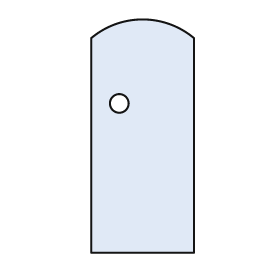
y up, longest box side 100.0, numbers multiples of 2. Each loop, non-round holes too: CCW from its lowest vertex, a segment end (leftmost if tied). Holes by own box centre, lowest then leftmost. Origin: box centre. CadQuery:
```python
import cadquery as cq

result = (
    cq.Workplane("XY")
    .moveTo(-22.0, -50.0)
    .lineTo(22.0, -50.0)
    .lineTo(22.0, 42.0)
    .threePointArc((0.0, 50.0), (-22.0, 42.0))
    .close()
    .moveTo(-10.0, 14.0)
    .circle(4.0)
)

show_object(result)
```